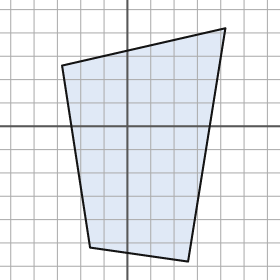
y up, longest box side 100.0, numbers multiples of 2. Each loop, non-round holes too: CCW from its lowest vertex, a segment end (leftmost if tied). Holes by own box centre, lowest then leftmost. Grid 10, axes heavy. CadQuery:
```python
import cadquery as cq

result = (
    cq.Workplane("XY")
    .moveTo(26.0, -58.0)
    .lineTo(42.0, 42.0)
    .lineTo(-28.0, 26.0)
    .lineTo(-16.0, -52.0)
    .close()
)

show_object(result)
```